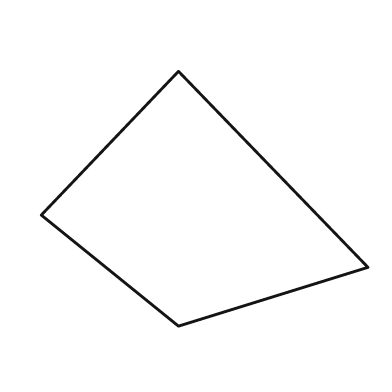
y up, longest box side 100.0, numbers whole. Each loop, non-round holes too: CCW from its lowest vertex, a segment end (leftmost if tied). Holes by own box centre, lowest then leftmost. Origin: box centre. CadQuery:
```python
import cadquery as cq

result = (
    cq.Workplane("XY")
    .moveTo(-8.0, -39.0)
    .lineTo(50.0, -21.0)
    .lineTo(-8.0, 39.0)
    .lineTo(-50.0, -5.0)
    .close()
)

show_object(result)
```